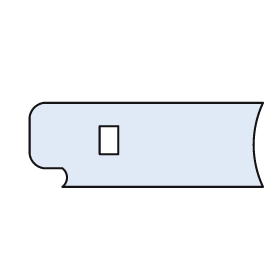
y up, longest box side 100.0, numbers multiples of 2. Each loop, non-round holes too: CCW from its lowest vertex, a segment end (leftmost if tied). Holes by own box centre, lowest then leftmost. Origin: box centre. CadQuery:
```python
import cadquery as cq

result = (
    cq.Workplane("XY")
    .moveTo(-36.0, -18.0)
    .lineTo(50.0, -18.0)
    .threePointArc((46.0, 0.0), (50.0, 18.0))
    .lineTo(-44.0, 18.0)
    .threePointArc((-48.0, 16.0), (-50.0, 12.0))
    .lineTo(-50.0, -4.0)
    .threePointArc((-48.0, -8.0), (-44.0, -10.0))
    .lineTo(-36.0, -10.0)
    .threePointArc((-34.0, -14.0), (-36.0, -18.0))
    .close()
    .moveTo(-20.0, -4.0)
    .lineTo(-12.0, -4.0)
    .lineTo(-12.0, 8.0)
    .lineTo(-20.0, 8.0)
    .close()
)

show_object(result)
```